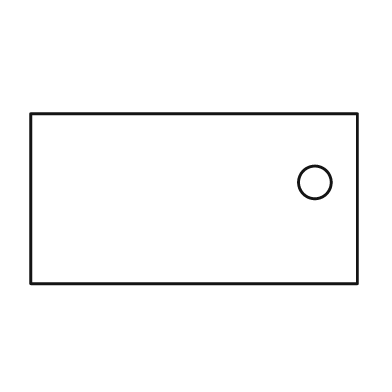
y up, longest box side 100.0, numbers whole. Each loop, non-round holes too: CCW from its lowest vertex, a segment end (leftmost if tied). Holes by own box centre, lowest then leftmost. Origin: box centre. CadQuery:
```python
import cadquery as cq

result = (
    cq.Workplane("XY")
    .moveTo(-50.0, -26.0)
    .lineTo(50.0, -26.0)
    .lineTo(50.0, 26.0)
    .lineTo(-50.0, 26.0)
    .close()
    .moveTo(37.0, 5.0)
    .circle(5.0)
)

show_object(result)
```